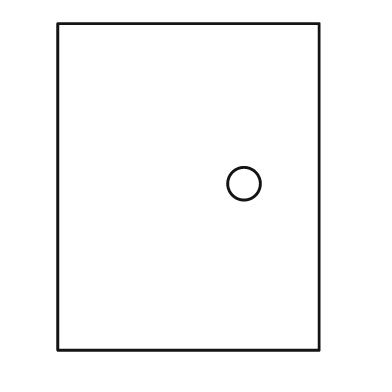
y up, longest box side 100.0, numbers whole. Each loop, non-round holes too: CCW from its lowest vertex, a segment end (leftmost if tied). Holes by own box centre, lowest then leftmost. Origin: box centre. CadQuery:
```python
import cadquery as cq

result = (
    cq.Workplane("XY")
    .moveTo(-40.0, -50.0)
    .lineTo(40.0, -50.0)
    .lineTo(40.0, 50.0)
    .lineTo(-40.0, 50.0)
    .close()
    .moveTo(17.0, 1.0)
    .circle(5.0)
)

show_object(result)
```